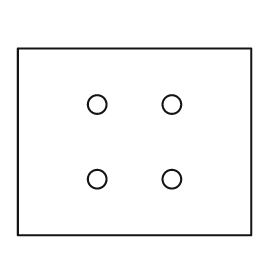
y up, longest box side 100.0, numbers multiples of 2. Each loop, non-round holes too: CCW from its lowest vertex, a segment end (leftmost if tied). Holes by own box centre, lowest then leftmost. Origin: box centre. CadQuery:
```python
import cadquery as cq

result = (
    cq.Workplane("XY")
    .moveTo(-50.0, -40.0)
    .lineTo(50.0, -40.0)
    .lineTo(50.0, 40.0)
    .lineTo(-50.0, 40.0)
    .close()
    .moveTo(-16.0, -16.0)
    .circle(4.0)
    .moveTo(16.0, -16.0)
    .circle(4.0)
    .moveTo(-16.0, 16.0)
    .circle(4.0)
    .moveTo(16.0, 16.0)
    .circle(4.0)
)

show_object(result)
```